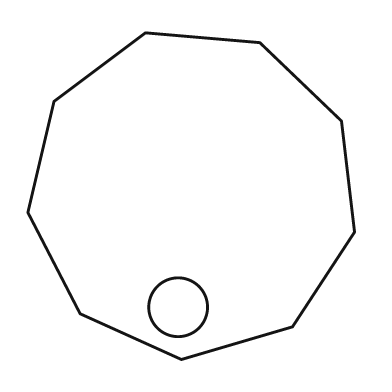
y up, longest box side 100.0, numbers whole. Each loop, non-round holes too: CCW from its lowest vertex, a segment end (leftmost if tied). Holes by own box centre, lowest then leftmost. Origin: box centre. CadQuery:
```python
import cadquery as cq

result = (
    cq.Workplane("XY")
    .moveTo(-3.0, -50.0)
    .lineTo(31.0, -40.0)
    .lineTo(50.0, -11.0)
    .lineTo(46.0, 23.0)
    .lineTo(21.0, 47.0)
    .lineTo(-14.0, 50.0)
    .lineTo(-42.0, 29.0)
    .lineTo(-50.0, -5.0)
    .lineTo(-34.0, -36.0)
    .close()
    .moveTo(-4.0, -34.0)
    .circle(9.0)
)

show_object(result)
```